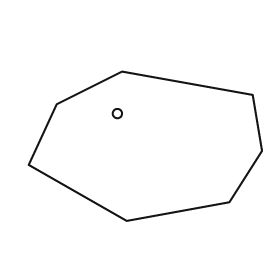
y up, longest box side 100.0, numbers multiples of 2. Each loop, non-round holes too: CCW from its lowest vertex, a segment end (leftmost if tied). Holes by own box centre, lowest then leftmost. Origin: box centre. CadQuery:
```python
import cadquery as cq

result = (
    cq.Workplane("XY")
    .moveTo(-8.0, -32.0)
    .lineTo(36.0, -24.0)
    .lineTo(50.0, -2.0)
    .lineTo(46.0, 22.0)
    .lineTo(-10.0, 32.0)
    .lineTo(-38.0, 18.0)
    .lineTo(-50.0, -8.0)
    .close()
    .moveTo(-12.0, 14.0)
    .circle(2.0)
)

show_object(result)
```